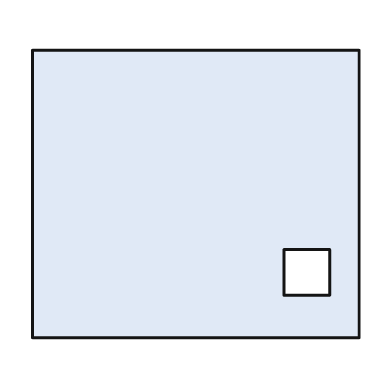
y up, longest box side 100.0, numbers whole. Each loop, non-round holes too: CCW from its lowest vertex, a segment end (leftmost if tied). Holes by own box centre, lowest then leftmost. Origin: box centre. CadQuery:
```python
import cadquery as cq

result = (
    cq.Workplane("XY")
    .moveTo(-50.0, -44.0)
    .lineTo(50.0, -44.0)
    .lineTo(50.0, 44.0)
    .lineTo(-50.0, 44.0)
    .close()
    .moveTo(27.0, -31.0)
    .lineTo(41.0, -31.0)
    .lineTo(41.0, -17.0)
    .lineTo(27.0, -17.0)
    .close()
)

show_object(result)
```